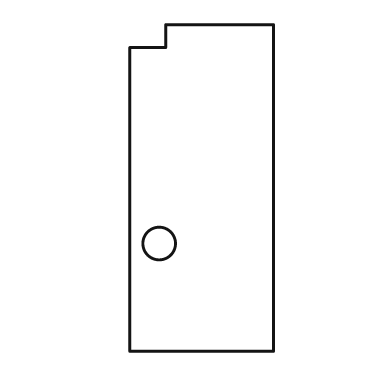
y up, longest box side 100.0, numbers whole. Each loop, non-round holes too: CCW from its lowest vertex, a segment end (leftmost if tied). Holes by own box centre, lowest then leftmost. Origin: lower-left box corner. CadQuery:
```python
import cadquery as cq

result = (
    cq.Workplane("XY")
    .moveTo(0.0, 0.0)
    .lineTo(44.0, 0.0)
    .lineTo(44.0, 100.0)
    .lineTo(11.0, 100.0)
    .lineTo(11.0, 93.0)
    .lineTo(0.0, 93.0)
    .close()
    .moveTo(9.0, 33.0)
    .circle(5.0)
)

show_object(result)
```